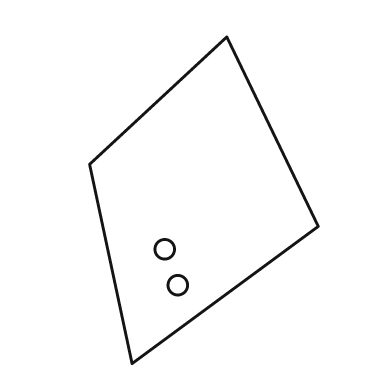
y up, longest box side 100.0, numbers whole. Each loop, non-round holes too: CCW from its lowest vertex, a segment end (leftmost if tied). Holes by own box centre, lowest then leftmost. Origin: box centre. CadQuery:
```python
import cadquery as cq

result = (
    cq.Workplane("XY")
    .moveTo(-22.0, -50.0)
    .lineTo(35.0, -8.0)
    .lineTo(7.0, 50.0)
    .lineTo(-35.0, 11.0)
    .close()
    .moveTo(-8.0, -26.0)
    .circle(3.0)
    .moveTo(-12.0, -15.0)
    .circle(3.0)
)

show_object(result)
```